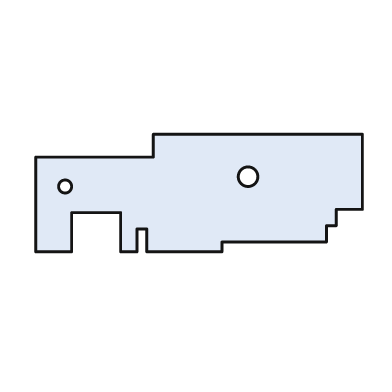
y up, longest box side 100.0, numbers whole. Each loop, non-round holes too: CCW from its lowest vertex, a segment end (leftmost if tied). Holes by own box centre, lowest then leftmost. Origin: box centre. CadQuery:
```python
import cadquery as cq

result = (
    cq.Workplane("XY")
    .moveTo(-50.0, -18.0)
    .lineTo(-39.0, -18.0)
    .lineTo(-39.0, -6.0)
    .lineTo(-24.0, -6.0)
    .lineTo(-24.0, -18.0)
    .lineTo(-19.0, -18.0)
    .lineTo(-19.0, -11.0)
    .lineTo(-16.0, -11.0)
    .lineTo(-16.0, -18.0)
    .lineTo(7.0, -18.0)
    .lineTo(7.0, -15.0)
    .lineTo(39.0, -15.0)
    .lineTo(39.0, -10.0)
    .lineTo(42.0, -10.0)
    .lineTo(42.0, -5.0)
    .lineTo(50.0, -5.0)
    .lineTo(50.0, 18.0)
    .lineTo(-14.0, 18.0)
    .lineTo(-14.0, 11.0)
    .lineTo(-50.0, 11.0)
    .close()
    .moveTo(-41.0, 2.0)
    .circle(2.0)
    .moveTo(15.0, 5.0)
    .circle(3.0)
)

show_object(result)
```